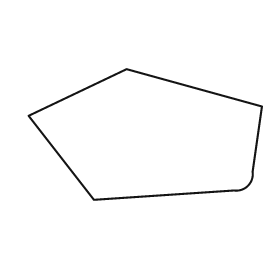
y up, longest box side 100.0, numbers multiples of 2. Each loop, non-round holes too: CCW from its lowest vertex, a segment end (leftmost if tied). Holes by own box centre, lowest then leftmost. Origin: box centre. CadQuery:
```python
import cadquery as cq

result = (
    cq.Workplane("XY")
    .moveTo(-22.0, -28.0)
    .lineTo(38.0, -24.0)
    .threePointArc((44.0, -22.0), (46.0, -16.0))
    .lineTo(50.0, 12.0)
    .lineTo(-8.0, 28.0)
    .lineTo(-50.0, 8.0)
    .close()
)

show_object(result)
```